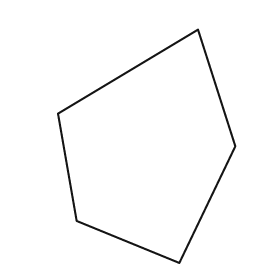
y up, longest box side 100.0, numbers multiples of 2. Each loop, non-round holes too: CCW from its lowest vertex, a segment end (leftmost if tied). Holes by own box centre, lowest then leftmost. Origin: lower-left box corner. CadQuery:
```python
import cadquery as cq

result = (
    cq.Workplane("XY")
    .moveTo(52.0, 0.0)
    .lineTo(76.0, 50.0)
    .lineTo(60.0, 100.0)
    .lineTo(0.0, 64.0)
    .lineTo(8.0, 18.0)
    .close()
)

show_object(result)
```